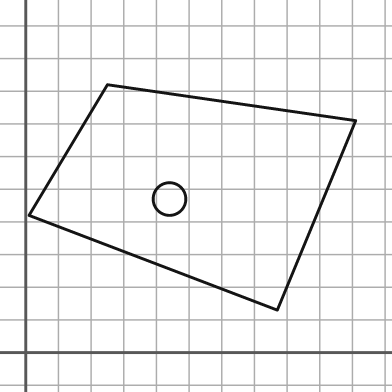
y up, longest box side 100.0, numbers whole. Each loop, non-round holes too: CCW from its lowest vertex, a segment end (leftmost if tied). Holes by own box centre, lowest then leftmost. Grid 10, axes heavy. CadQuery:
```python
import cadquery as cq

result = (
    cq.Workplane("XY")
    .moveTo(77.0, 13.0)
    .lineTo(101.0, 71.0)
    .lineTo(25.0, 82.0)
    .lineTo(1.0, 42.0)
    .close()
    .moveTo(44.0, 47.0)
    .circle(5.0)
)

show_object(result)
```